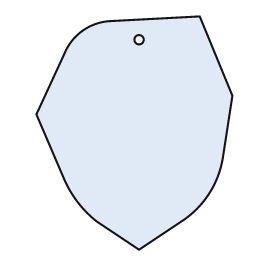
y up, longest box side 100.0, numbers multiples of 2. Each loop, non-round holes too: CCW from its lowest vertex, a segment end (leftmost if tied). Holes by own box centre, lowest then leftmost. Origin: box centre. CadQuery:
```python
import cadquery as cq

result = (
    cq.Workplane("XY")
    .moveTo(2.0, -50.0)
    .lineTo(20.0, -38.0)
    .threePointArc((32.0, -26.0), (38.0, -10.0))
    .lineTo(42.0, 16.0)
    .lineTo(28.0, 50.0)
    .lineTo(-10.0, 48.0)
    .threePointArc((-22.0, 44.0), (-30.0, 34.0))
    .lineTo(-42.0, 8.0)
    .lineTo(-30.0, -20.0)
    .threePointArc((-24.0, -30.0), (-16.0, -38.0))
    .close()
    .moveTo(2.0, 40.0)
    .circle(2.0)
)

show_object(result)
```